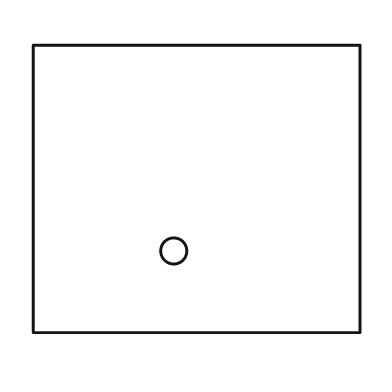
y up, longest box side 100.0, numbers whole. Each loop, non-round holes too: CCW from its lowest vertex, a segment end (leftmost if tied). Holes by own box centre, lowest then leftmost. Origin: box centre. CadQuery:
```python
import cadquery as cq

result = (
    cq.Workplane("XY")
    .moveTo(-50.0, -44.0)
    .lineTo(50.0, -44.0)
    .lineTo(50.0, 44.0)
    .lineTo(-50.0, 44.0)
    .close()
    .moveTo(-7.0, -19.0)
    .circle(4.0)
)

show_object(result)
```